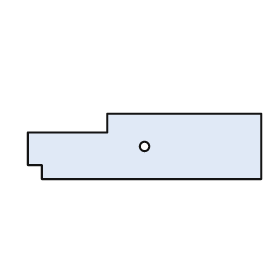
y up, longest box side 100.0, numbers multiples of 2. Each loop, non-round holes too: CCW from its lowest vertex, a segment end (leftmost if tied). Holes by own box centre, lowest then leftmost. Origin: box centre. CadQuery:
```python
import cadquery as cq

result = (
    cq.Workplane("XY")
    .moveTo(-44.0, -14.0)
    .lineTo(50.0, -14.0)
    .lineTo(50.0, 14.0)
    .lineTo(-16.0, 14.0)
    .lineTo(-16.0, 6.0)
    .lineTo(-50.0, 6.0)
    .lineTo(-50.0, -8.0)
    .lineTo(-44.0, -8.0)
    .close()
    .moveTo(0.0, 0.0)
    .circle(2.0)
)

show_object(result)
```